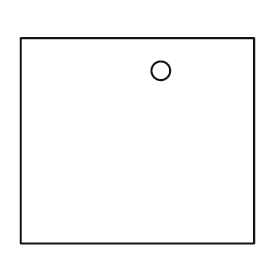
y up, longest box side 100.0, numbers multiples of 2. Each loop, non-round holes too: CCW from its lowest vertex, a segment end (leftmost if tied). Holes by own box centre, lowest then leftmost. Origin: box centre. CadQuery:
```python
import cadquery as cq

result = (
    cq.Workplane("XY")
    .moveTo(-50.0, -44.0)
    .lineTo(50.0, -44.0)
    .lineTo(50.0, 44.0)
    .lineTo(-50.0, 44.0)
    .close()
    .moveTo(10.0, 30.0)
    .circle(4.0)
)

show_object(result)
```